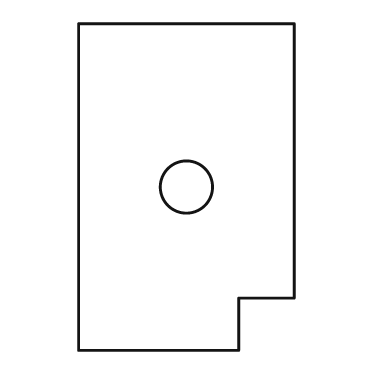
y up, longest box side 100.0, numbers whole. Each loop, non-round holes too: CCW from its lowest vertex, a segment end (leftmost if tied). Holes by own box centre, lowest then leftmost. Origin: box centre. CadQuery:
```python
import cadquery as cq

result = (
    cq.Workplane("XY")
    .moveTo(-33.0, -50.0)
    .lineTo(16.0, -50.0)
    .lineTo(16.0, -34.0)
    .lineTo(33.0, -34.0)
    .lineTo(33.0, 50.0)
    .lineTo(-33.0, 50.0)
    .close()
    .moveTo(0.0, 0.0)
    .circle(8.0)
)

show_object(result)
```